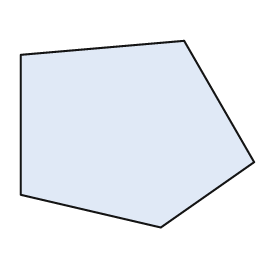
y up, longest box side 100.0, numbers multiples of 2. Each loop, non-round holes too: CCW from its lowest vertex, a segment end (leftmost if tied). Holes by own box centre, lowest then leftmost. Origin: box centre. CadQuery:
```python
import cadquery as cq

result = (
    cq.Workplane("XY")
    .moveTo(10.0, -40.0)
    .lineTo(50.0, -12.0)
    .lineTo(20.0, 40.0)
    .lineTo(-50.0, 34.0)
    .lineTo(-50.0, -26.0)
    .close()
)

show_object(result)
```